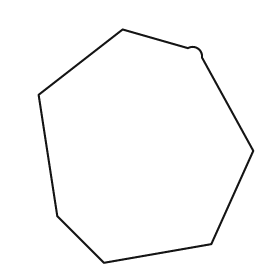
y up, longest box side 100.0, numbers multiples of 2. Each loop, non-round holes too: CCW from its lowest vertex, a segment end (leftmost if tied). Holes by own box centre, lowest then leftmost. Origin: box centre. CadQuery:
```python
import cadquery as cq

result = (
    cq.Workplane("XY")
    .moveTo(-18.0, -50.0)
    .lineTo(28.0, -42.0)
    .lineTo(46.0, -2.0)
    .lineTo(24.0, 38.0)
    .threePointArc((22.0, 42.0), (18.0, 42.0))
    .lineTo(-10.0, 50.0)
    .lineTo(-46.0, 22.0)
    .lineTo(-38.0, -30.0)
    .close()
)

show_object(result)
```